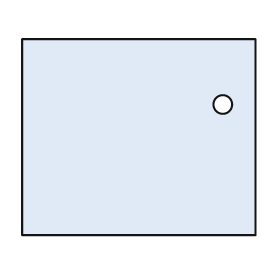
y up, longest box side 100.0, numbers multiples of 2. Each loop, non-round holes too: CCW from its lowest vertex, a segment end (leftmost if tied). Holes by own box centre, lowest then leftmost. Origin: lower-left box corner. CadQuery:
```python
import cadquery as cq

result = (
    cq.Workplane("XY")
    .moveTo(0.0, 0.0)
    .lineTo(100.0, 0.0)
    .lineTo(100.0, 84.0)
    .lineTo(0.0, 84.0)
    .close()
    .moveTo(86.0, 56.0)
    .circle(4.0)
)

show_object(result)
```